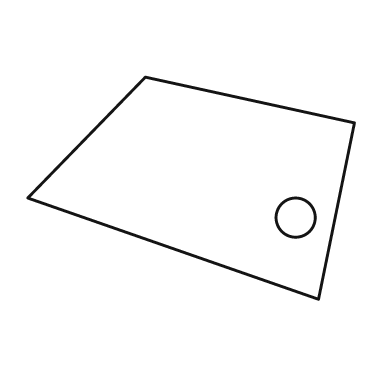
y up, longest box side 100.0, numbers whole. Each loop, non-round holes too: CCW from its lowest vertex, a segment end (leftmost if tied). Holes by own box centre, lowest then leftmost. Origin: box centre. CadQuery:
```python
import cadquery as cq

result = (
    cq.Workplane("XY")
    .moveTo(39.0, -34.0)
    .lineTo(50.0, 20.0)
    .lineTo(-14.0, 34.0)
    .lineTo(-50.0, -3.0)
    .close()
    .moveTo(32.0, -9.0)
    .circle(6.0)
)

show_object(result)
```